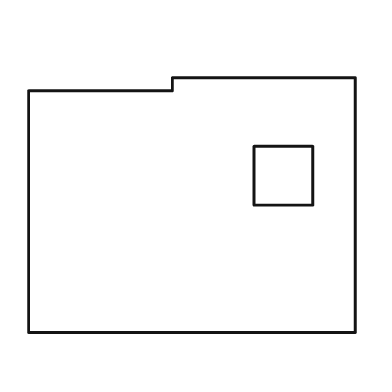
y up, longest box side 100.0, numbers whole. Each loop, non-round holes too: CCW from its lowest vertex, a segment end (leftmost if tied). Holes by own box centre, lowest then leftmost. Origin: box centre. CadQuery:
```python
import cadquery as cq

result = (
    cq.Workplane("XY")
    .moveTo(-50.0, -39.0)
    .lineTo(50.0, -39.0)
    .lineTo(50.0, 39.0)
    .lineTo(-6.0, 39.0)
    .lineTo(-6.0, 35.0)
    .lineTo(-50.0, 35.0)
    .close()
    .moveTo(19.0, 0.0)
    .lineTo(37.0, 0.0)
    .lineTo(37.0, 18.0)
    .lineTo(19.0, 18.0)
    .close()
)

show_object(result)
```